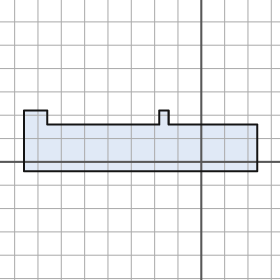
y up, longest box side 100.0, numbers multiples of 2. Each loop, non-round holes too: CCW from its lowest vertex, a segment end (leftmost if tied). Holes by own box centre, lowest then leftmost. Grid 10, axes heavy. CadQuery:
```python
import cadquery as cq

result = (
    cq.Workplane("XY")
    .moveTo(-76.0, -4.0)
    .lineTo(24.0, -4.0)
    .lineTo(24.0, 16.0)
    .lineTo(-14.0, 16.0)
    .lineTo(-14.0, 22.0)
    .lineTo(-18.0, 22.0)
    .lineTo(-18.0, 16.0)
    .lineTo(-66.0, 16.0)
    .lineTo(-66.0, 22.0)
    .lineTo(-76.0, 22.0)
    .close()
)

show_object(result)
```